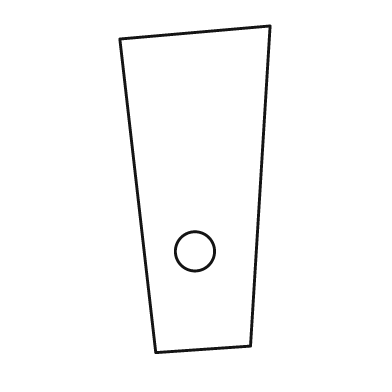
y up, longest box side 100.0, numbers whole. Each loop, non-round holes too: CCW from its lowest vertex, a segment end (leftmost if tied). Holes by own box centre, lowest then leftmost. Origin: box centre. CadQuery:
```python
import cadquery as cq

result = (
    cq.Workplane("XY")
    .moveTo(-12.0, -50.0)
    .lineTo(17.0, -48.0)
    .lineTo(23.0, 50.0)
    .lineTo(-23.0, 46.0)
    .close()
    .moveTo(0.0, -19.0)
    .circle(6.0)
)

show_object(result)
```